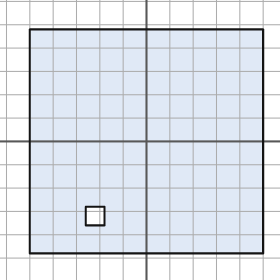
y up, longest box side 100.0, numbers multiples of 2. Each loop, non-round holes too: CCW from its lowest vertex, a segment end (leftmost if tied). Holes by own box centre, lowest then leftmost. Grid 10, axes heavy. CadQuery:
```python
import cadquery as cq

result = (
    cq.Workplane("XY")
    .moveTo(-50.0, -48.0)
    .lineTo(50.0, -48.0)
    .lineTo(50.0, 48.0)
    .lineTo(-50.0, 48.0)
    .close()
    .moveTo(-26.0, -36.0)
    .lineTo(-18.0, -36.0)
    .lineTo(-18.0, -28.0)
    .lineTo(-26.0, -28.0)
    .close()
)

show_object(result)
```